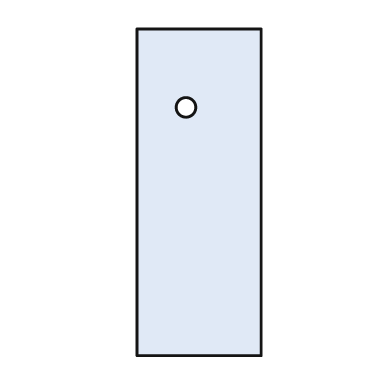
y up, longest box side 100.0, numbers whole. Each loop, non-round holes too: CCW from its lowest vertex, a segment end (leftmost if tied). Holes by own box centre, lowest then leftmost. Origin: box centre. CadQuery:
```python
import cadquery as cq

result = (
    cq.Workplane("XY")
    .moveTo(-19.0, -50.0)
    .lineTo(19.0, -50.0)
    .lineTo(19.0, 50.0)
    .lineTo(-19.0, 50.0)
    .close()
    .moveTo(-4.0, 26.0)
    .circle(3.0)
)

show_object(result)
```